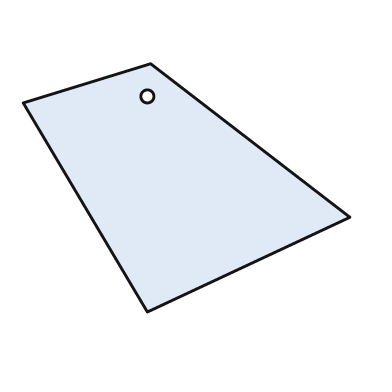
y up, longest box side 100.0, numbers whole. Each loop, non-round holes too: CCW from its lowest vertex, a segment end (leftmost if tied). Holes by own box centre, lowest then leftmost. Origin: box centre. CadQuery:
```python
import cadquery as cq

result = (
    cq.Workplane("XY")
    .moveTo(-12.0, -38.0)
    .lineTo(50.0, -9.0)
    .lineTo(-11.0, 38.0)
    .lineTo(-50.0, 26.0)
    .close()
    .moveTo(-12.0, 28.0)
    .circle(2.0)
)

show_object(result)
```